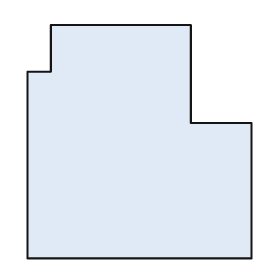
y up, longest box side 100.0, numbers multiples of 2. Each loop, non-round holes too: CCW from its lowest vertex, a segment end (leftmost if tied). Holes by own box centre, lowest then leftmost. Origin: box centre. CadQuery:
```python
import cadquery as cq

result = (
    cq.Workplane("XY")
    .moveTo(-48.0, -50.0)
    .lineTo(48.0, -50.0)
    .lineTo(48.0, 8.0)
    .lineTo(22.0, 8.0)
    .lineTo(22.0, 50.0)
    .lineTo(-38.0, 50.0)
    .lineTo(-38.0, 30.0)
    .lineTo(-48.0, 30.0)
    .close()
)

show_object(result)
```